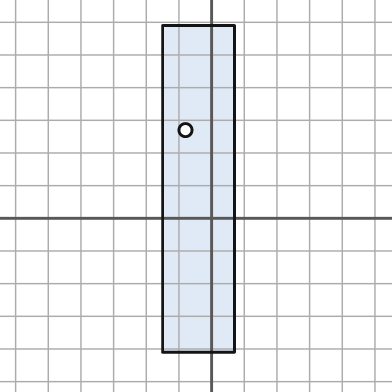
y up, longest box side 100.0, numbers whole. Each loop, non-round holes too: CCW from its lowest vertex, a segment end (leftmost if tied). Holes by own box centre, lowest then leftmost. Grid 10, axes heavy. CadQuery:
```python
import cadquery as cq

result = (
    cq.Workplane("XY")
    .moveTo(-15.0, -41.0)
    .lineTo(7.0, -41.0)
    .lineTo(7.0, 59.0)
    .lineTo(-15.0, 59.0)
    .close()
    .moveTo(-8.0, 27.0)
    .circle(2.0)
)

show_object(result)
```